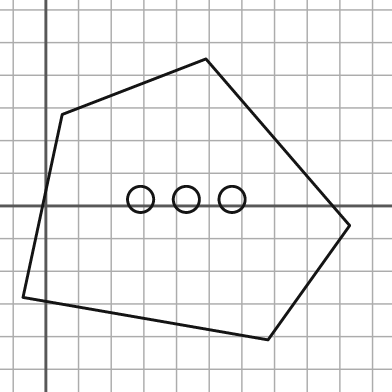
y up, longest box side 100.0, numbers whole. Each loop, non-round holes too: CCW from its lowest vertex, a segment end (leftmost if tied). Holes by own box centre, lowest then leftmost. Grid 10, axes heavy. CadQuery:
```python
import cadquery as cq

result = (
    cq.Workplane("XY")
    .moveTo(68.0, -41.0)
    .lineTo(93.0, -6.0)
    .lineTo(49.0, 45.0)
    .lineTo(5.0, 28.0)
    .lineTo(-7.0, -28.0)
    .close()
    .moveTo(29.0, 2.0)
    .circle(4.0)
    .moveTo(43.0, 2.0)
    .circle(4.0)
    .moveTo(57.0, 2.0)
    .circle(4.0)
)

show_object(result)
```